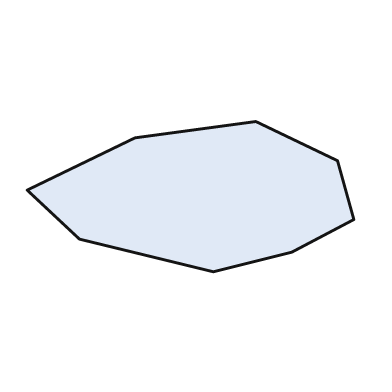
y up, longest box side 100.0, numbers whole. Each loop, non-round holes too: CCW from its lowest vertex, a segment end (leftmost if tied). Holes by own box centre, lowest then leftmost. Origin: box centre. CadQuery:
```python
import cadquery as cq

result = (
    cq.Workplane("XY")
    .moveTo(7.0, -23.0)
    .lineTo(31.0, -17.0)
    .lineTo(50.0, -7.0)
    .lineTo(45.0, 11.0)
    .lineTo(20.0, 23.0)
    .lineTo(-17.0, 18.0)
    .lineTo(-50.0, 2.0)
    .lineTo(-34.0, -13.0)
    .close()
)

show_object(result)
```